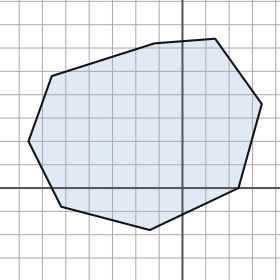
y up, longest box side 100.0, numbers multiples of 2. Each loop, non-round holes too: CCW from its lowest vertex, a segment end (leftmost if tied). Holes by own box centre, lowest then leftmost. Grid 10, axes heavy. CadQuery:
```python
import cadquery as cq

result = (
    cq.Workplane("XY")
    .moveTo(-14.0, -18.0)
    .lineTo(24.0, 0.0)
    .lineTo(34.0, 36.0)
    .lineTo(14.0, 64.0)
    .lineTo(-12.0, 62.0)
    .lineTo(-56.0, 48.0)
    .lineTo(-66.0, 20.0)
    .lineTo(-52.0, -8.0)
    .close()
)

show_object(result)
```